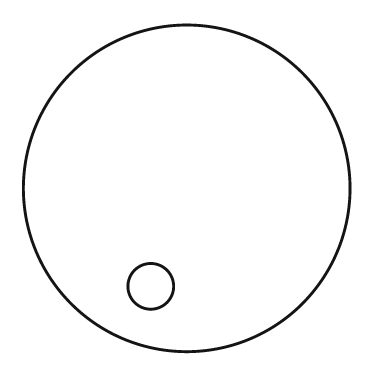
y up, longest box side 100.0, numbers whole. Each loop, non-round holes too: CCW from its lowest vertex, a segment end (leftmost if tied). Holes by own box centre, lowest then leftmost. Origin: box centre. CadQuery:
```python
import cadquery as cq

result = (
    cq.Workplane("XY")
    .moveTo(0.0, 0.0)
    .circle(50.0)
    .moveTo(-11.0, -30.0)
    .circle(7.0)
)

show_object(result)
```